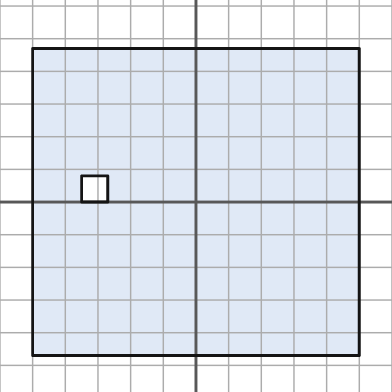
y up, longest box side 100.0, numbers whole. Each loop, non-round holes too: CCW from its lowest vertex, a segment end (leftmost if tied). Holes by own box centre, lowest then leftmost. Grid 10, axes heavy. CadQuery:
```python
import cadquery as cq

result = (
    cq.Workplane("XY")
    .moveTo(-50.0, -47.0)
    .lineTo(50.0, -47.0)
    .lineTo(50.0, 47.0)
    .lineTo(-50.0, 47.0)
    .close()
    .moveTo(-35.0, 0.0)
    .lineTo(-27.0, 0.0)
    .lineTo(-27.0, 8.0)
    .lineTo(-35.0, 8.0)
    .close()
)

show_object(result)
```